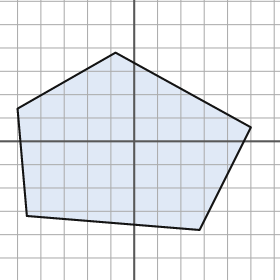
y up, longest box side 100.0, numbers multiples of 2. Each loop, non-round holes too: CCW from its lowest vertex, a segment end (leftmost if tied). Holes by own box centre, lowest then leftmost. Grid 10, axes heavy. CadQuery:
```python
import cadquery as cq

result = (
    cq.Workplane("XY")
    .moveTo(28.0, -38.0)
    .lineTo(50.0, 6.0)
    .lineTo(-8.0, 38.0)
    .lineTo(-50.0, 14.0)
    .lineTo(-46.0, -32.0)
    .close()
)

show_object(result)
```